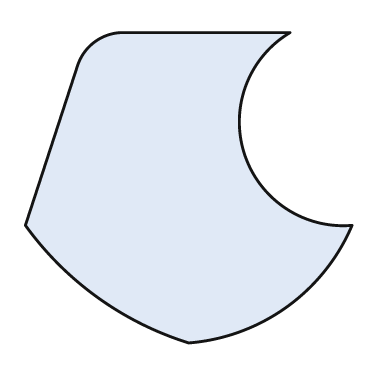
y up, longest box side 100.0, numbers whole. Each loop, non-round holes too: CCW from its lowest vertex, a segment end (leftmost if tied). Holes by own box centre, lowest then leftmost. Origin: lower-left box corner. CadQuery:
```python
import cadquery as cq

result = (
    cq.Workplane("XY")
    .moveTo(50.0, 0.0)
    .threePointArc((80.0, 11.0), (100.0, 36.0))
    .threePointArc((67.0, 58.0), (81.0, 95.0))
    .lineTo(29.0, 95.0)
    .threePointArc((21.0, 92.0), (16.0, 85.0))
    .lineTo(0.0, 36.0)
    .threePointArc((22.0, 14.0), (50.0, 0.0))
    .close()
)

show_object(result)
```